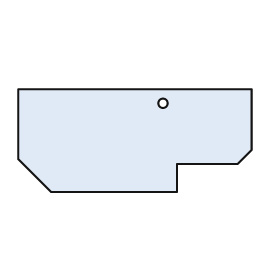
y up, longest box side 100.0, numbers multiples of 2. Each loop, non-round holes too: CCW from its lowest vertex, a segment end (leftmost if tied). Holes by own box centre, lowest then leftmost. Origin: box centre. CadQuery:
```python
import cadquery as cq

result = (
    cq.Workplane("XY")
    .moveTo(-36.0, -22.0)
    .lineTo(18.0, -22.0)
    .lineTo(18.0, -10.0)
    .lineTo(44.0, -10.0)
    .lineTo(50.0, -4.0)
    .lineTo(50.0, 22.0)
    .lineTo(-50.0, 22.0)
    .lineTo(-50.0, -8.0)
    .close()
    .moveTo(12.0, 16.0)
    .circle(2.0)
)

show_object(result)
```